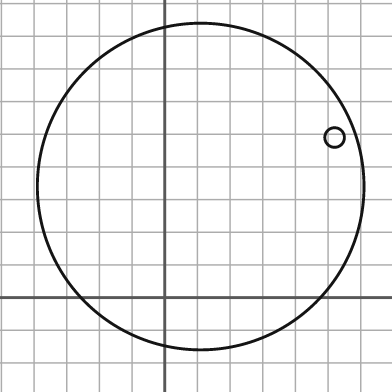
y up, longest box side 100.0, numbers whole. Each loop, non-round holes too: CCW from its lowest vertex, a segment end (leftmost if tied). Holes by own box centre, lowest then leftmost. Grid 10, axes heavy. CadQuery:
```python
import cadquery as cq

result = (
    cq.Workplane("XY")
    .moveTo(11.0, 34.0)
    .circle(50.0)
    .moveTo(52.0, 49.0)
    .circle(3.0)
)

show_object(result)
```